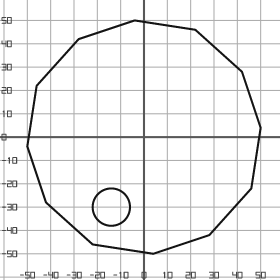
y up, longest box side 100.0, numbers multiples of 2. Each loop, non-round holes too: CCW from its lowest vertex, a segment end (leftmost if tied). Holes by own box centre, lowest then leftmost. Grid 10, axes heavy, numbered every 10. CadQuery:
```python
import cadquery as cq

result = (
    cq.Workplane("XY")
    .moveTo(4.0, -50.0)
    .lineTo(28.0, -42.0)
    .lineTo(46.0, -22.0)
    .lineTo(50.0, 4.0)
    .lineTo(42.0, 28.0)
    .lineTo(22.0, 46.0)
    .lineTo(-4.0, 50.0)
    .lineTo(-28.0, 42.0)
    .lineTo(-46.0, 22.0)
    .lineTo(-50.0, -4.0)
    .lineTo(-42.0, -28.0)
    .lineTo(-22.0, -46.0)
    .close()
    .moveTo(-14.0, -30.0)
    .circle(8.0)
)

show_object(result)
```